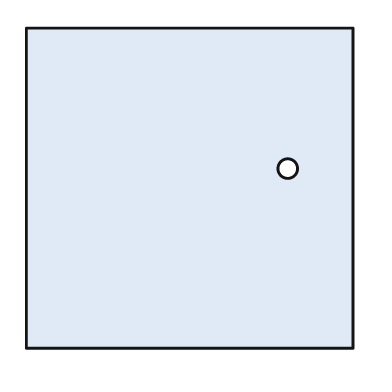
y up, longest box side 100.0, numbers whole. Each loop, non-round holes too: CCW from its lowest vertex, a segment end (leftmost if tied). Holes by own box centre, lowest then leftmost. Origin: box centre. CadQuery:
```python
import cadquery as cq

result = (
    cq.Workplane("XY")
    .moveTo(-50.0, -49.0)
    .lineTo(50.0, -49.0)
    .lineTo(50.0, 49.0)
    .lineTo(-50.0, 49.0)
    .close()
    .moveTo(30.0, 6.0)
    .circle(3.0)
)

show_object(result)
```